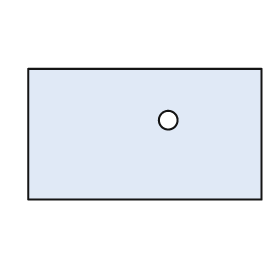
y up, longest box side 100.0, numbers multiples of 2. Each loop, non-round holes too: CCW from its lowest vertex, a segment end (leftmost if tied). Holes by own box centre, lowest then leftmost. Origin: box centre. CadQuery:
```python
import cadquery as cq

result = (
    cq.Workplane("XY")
    .moveTo(-50.0, -28.0)
    .lineTo(50.0, -28.0)
    .lineTo(50.0, 28.0)
    .lineTo(-50.0, 28.0)
    .close()
    .moveTo(10.0, 6.0)
    .circle(4.0)
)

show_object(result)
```